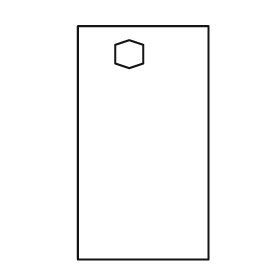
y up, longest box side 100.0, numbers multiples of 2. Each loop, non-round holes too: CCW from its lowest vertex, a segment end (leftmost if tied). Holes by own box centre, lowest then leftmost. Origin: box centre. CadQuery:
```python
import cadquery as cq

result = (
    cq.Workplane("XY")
    .moveTo(-28.0, -50.0)
    .lineTo(28.0, -50.0)
    .lineTo(28.0, 50.0)
    .lineTo(-28.0, 50.0)
    .close()
    .moveTo(-6.0, 32.0)
    .lineTo(0.0, 34.0)
    .lineTo(0.0, 42.0)
    .lineTo(-6.0, 44.0)
    .lineTo(-12.0, 42.0)
    .lineTo(-12.0, 34.0)
    .close()
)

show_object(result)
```